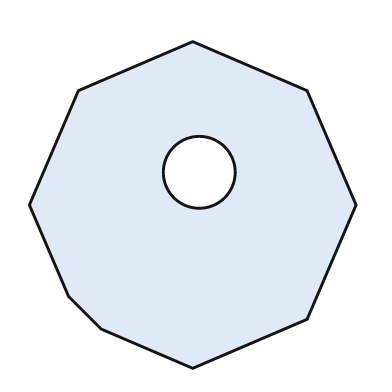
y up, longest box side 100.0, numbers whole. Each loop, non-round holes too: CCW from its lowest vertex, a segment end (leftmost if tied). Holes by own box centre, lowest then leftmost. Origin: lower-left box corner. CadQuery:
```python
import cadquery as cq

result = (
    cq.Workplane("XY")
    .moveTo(50.0, 0.0)
    .lineTo(85.0, 15.0)
    .lineTo(100.0, 50.0)
    .lineTo(85.0, 85.0)
    .lineTo(50.0, 100.0)
    .lineTo(15.0, 85.0)
    .lineTo(0.0, 50.0)
    .lineTo(12.0, 22.0)
    .lineTo(22.0, 12.0)
    .close()
    .moveTo(52.0, 60.0)
    .circle(11.0)
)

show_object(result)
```